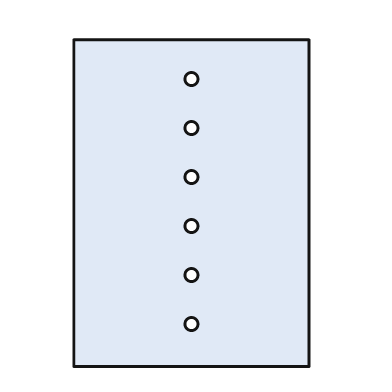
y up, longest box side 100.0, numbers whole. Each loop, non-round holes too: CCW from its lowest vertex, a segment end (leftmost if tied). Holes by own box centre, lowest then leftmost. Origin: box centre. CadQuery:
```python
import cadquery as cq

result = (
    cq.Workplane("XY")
    .moveTo(-36.0, -50.0)
    .lineTo(36.0, -50.0)
    .lineTo(36.0, 50.0)
    .lineTo(-36.0, 50.0)
    .close()
    .moveTo(0.0, -37.0)
    .circle(2.0)
    .moveTo(0.0, -22.0)
    .circle(2.0)
    .moveTo(0.0, -7.0)
    .circle(2.0)
    .moveTo(0.0, 8.0)
    .circle(2.0)
    .moveTo(0.0, 23.0)
    .circle(2.0)
    .moveTo(0.0, 38.0)
    .circle(2.0)
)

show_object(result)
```